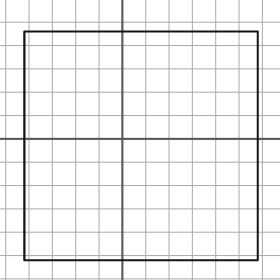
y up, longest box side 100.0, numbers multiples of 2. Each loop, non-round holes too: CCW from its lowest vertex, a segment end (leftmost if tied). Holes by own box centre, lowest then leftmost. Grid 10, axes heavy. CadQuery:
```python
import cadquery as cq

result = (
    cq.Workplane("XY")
    .moveTo(-42.0, -52.0)
    .lineTo(58.0, -52.0)
    .lineTo(58.0, 46.0)
    .lineTo(-42.0, 46.0)
    .close()
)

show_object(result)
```